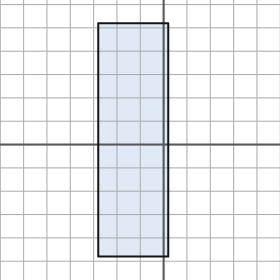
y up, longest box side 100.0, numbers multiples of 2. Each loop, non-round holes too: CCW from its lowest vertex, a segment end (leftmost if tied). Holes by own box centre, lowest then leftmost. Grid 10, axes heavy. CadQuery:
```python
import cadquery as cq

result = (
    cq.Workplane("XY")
    .moveTo(-28.0, -48.0)
    .lineTo(2.0, -48.0)
    .lineTo(2.0, 52.0)
    .lineTo(-28.0, 52.0)
    .close()
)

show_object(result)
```